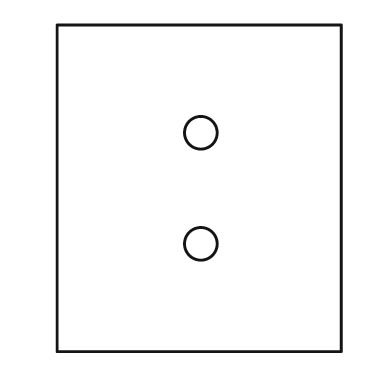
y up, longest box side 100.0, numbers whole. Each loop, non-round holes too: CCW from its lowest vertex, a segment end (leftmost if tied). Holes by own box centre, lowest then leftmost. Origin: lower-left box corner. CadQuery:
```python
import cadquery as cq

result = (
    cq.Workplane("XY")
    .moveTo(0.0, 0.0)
    .lineTo(87.0, 0.0)
    .lineTo(87.0, 100.0)
    .lineTo(0.0, 100.0)
    .close()
    .moveTo(44.0, 33.0)
    .circle(5.0)
    .moveTo(44.0, 67.0)
    .circle(5.0)
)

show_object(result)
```